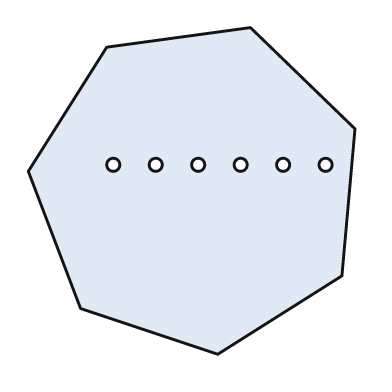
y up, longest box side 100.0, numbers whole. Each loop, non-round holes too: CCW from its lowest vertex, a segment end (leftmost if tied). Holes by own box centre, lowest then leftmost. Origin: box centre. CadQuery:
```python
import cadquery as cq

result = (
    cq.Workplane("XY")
    .moveTo(8.0, -50.0)
    .lineTo(46.0, -26.0)
    .lineTo(50.0, 19.0)
    .lineTo(18.0, 50.0)
    .lineTo(-26.0, 44.0)
    .lineTo(-50.0, 6.0)
    .lineTo(-34.0, -36.0)
    .close()
    .moveTo(-24.0, 8.0)
    .circle(2.0)
    .moveTo(-11.0, 8.0)
    .circle(2.0)
    .moveTo(2.0, 8.0)
    .circle(2.0)
    .moveTo(15.0, 8.0)
    .circle(2.0)
    .moveTo(28.0, 8.0)
    .circle(2.0)
    .moveTo(41.0, 8.0)
    .circle(2.0)
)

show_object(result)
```